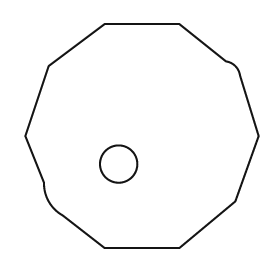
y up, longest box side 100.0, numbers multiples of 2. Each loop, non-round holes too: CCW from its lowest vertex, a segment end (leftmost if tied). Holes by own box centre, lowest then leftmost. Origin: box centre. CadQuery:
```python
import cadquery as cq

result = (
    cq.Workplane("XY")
    .moveTo(-16.0, -48.0)
    .lineTo(16.0, -48.0)
    .lineTo(40.0, -28.0)
    .lineTo(50.0, 0.0)
    .lineTo(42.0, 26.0)
    .threePointArc((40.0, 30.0), (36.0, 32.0))
    .lineTo(16.0, 48.0)
    .lineTo(-16.0, 48.0)
    .lineTo(-40.0, 30.0)
    .lineTo(-50.0, 0.0)
    .lineTo(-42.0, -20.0)
    .threePointArc((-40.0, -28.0), (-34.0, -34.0))
    .close()
    .moveTo(-10.0, -12.0)
    .circle(8.0)
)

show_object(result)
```